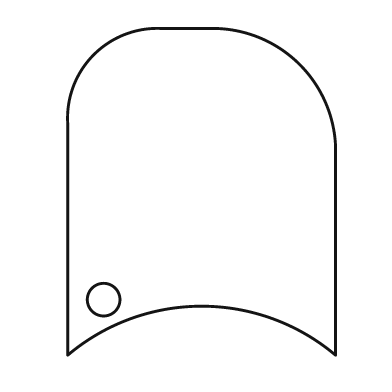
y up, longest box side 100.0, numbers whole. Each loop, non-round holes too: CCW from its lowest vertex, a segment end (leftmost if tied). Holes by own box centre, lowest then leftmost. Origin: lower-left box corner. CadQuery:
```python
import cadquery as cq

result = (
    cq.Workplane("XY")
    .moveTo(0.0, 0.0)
    .threePointArc((41.0, 15.0), (82.0, 0.0))
    .lineTo(82.0, 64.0)
    .threePointArc((71.0, 89.0), (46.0, 100.0))
    .lineTo(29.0, 100.0)
    .threePointArc((8.0, 92.0), (0.0, 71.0))
    .close()
    .moveTo(11.0, 17.0)
    .circle(5.0)
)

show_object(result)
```